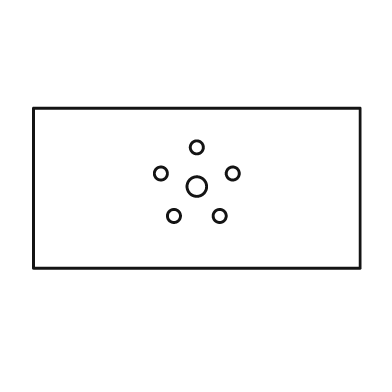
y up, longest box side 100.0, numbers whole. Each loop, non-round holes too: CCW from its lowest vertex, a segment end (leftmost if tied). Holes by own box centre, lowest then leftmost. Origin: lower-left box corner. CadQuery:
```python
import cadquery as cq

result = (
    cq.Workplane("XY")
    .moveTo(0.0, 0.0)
    .lineTo(100.0, 0.0)
    .lineTo(100.0, 49.0)
    .lineTo(0.0, 49.0)
    .close()
    .moveTo(43.0, 16.0)
    .circle(2.0)
    .moveTo(57.0, 16.0)
    .circle(2.0)
    .moveTo(50.0, 25.0)
    .circle(3.0)
    .moveTo(39.0, 29.0)
    .circle(2.0)
    .moveTo(61.0, 29.0)
    .circle(2.0)
    .moveTo(50.0, 37.0)
    .circle(2.0)
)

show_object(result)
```